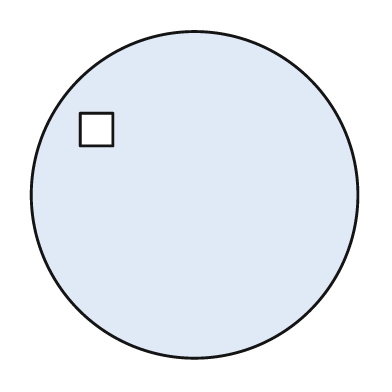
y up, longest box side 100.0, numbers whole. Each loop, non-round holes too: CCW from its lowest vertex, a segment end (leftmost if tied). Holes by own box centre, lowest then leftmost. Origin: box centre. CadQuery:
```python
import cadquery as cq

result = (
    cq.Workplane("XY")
    .moveTo(0.0, 0.0)
    .circle(50.0)
    .moveTo(-35.0, 15.0)
    .lineTo(-25.0, 15.0)
    .lineTo(-25.0, 25.0)
    .lineTo(-35.0, 25.0)
    .close()
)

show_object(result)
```